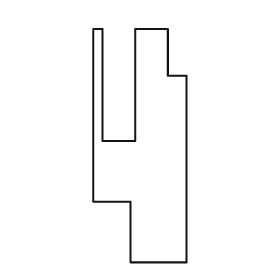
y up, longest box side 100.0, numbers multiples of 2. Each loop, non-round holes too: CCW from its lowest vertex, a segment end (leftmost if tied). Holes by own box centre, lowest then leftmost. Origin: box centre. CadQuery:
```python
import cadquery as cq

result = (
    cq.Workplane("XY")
    .moveTo(-4.0, -50.0)
    .lineTo(20.0, -50.0)
    .lineTo(20.0, 30.0)
    .lineTo(12.0, 30.0)
    .lineTo(12.0, 50.0)
    .lineTo(-2.0, 50.0)
    .lineTo(-2.0, 2.0)
    .lineTo(-16.0, 2.0)
    .lineTo(-16.0, 50.0)
    .lineTo(-20.0, 50.0)
    .lineTo(-20.0, -24.0)
    .lineTo(-4.0, -24.0)
    .close()
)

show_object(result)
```